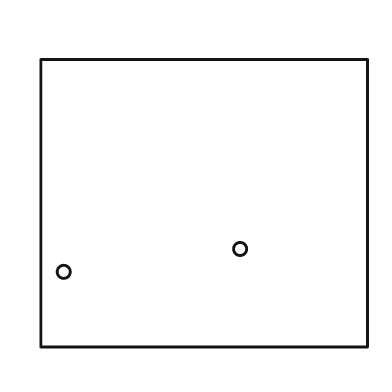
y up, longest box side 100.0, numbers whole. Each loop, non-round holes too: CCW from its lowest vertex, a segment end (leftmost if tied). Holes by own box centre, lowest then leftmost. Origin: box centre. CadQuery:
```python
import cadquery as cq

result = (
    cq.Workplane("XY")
    .moveTo(-50.0, -44.0)
    .lineTo(50.0, -44.0)
    .lineTo(50.0, 44.0)
    .lineTo(-50.0, 44.0)
    .close()
    .moveTo(-43.0, -21.0)
    .circle(2.0)
    .moveTo(11.0, -14.0)
    .circle(2.0)
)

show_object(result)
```